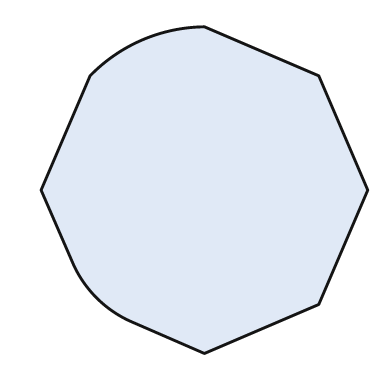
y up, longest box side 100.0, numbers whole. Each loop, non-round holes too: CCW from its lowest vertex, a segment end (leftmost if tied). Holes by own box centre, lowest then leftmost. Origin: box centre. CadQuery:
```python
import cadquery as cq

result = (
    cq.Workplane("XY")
    .moveTo(0.0, -50.0)
    .lineTo(35.0, -35.0)
    .lineTo(50.0, 0.0)
    .lineTo(35.0, 35.0)
    .lineTo(0.0, 50.0)
    .threePointArc((-19.0, 46.0), (-35.0, 35.0))
    .lineTo(-50.0, 0.0)
    .lineTo(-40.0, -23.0)
    .threePointArc((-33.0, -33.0), (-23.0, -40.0))
    .close()
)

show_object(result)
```